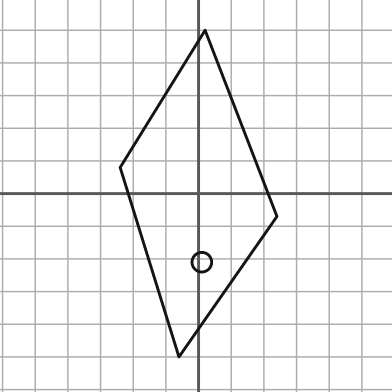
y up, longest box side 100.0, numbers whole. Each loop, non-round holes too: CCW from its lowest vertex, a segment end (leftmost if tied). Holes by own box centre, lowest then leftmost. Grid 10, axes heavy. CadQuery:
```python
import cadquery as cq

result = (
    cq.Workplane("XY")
    .moveTo(-6.0, -50.0)
    .lineTo(24.0, -7.0)
    .lineTo(2.0, 50.0)
    .lineTo(-24.0, 8.0)
    .close()
    .moveTo(1.0, -21.0)
    .circle(3.0)
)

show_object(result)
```